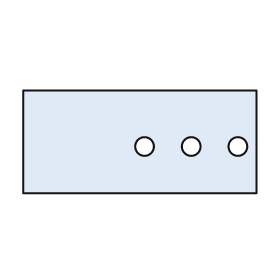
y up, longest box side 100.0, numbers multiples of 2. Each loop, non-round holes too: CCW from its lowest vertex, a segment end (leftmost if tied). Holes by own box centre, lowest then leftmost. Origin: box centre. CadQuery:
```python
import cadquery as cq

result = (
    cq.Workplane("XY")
    .moveTo(-50.0, -22.0)
    .lineTo(50.0, -22.0)
    .lineTo(50.0, 22.0)
    .lineTo(-50.0, 22.0)
    .close()
    .moveTo(2.0, -2.0)
    .circle(4.0)
    .moveTo(22.0, -2.0)
    .circle(4.0)
    .moveTo(42.0, -2.0)
    .circle(4.0)
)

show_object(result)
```